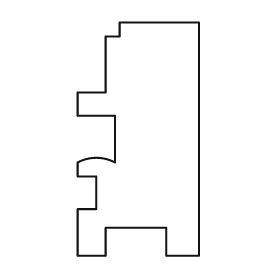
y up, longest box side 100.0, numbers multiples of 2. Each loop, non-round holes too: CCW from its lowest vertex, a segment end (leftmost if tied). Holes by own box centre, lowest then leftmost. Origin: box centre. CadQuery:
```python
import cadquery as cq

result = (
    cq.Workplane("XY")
    .moveTo(-26.0, -50.0)
    .lineTo(-14.0, -50.0)
    .lineTo(-14.0, -38.0)
    .lineTo(12.0, -38.0)
    .lineTo(12.0, -50.0)
    .lineTo(26.0, -50.0)
    .lineTo(26.0, 50.0)
    .lineTo(-8.0, 50.0)
    .lineTo(-8.0, 44.0)
    .lineTo(-14.0, 44.0)
    .lineTo(-14.0, 20.0)
    .lineTo(-26.0, 20.0)
    .lineTo(-26.0, 10.0)
    .lineTo(-10.0, 10.0)
    .lineTo(-10.0, -10.0)
    .threePointArc((-18.0, -8.0), (-26.0, -10.0))
    .lineTo(-26.0, -16.0)
    .lineTo(-18.0, -16.0)
    .lineTo(-18.0, -30.0)
    .lineTo(-26.0, -30.0)
    .close()
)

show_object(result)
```